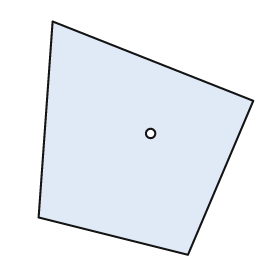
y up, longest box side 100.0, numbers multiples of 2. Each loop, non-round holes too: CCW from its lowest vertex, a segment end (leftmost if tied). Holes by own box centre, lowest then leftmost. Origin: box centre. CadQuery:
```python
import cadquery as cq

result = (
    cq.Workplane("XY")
    .moveTo(18.0, -50.0)
    .lineTo(46.0, 16.0)
    .lineTo(-40.0, 50.0)
    .lineTo(-46.0, -34.0)
    .close()
    .moveTo(2.0, 2.0)
    .circle(2.0)
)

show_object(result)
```